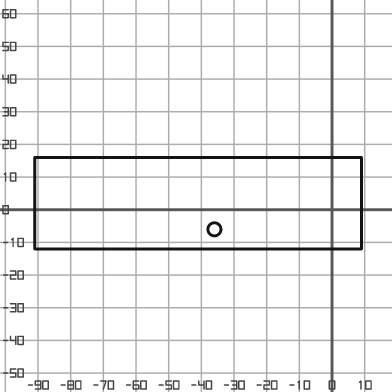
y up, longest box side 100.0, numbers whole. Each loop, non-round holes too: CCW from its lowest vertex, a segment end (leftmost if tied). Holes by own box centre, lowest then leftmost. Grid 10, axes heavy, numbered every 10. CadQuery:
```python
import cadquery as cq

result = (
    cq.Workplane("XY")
    .moveTo(-91.0, -12.0)
    .lineTo(9.0, -12.0)
    .lineTo(9.0, 16.0)
    .lineTo(-91.0, 16.0)
    .close()
    .moveTo(-36.0, -6.0)
    .circle(2.0)
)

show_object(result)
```